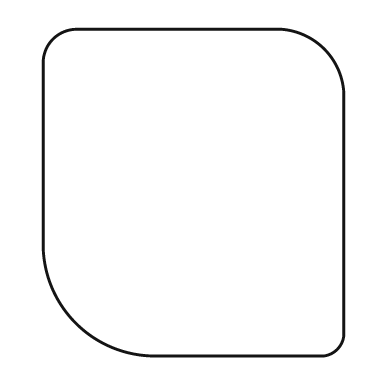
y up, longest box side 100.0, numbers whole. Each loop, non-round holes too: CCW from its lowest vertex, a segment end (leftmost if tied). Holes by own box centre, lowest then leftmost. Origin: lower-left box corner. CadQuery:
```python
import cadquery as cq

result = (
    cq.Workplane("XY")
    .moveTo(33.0, 0.0)
    .lineTo(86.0, 0.0)
    .threePointArc((90.0, 2.0), (92.0, 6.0))
    .lineTo(92.0, 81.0)
    .threePointArc((86.0, 94.0), (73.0, 100.0))
    .lineTo(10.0, 100.0)
    .threePointArc((3.0, 97.0), (0.0, 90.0))
    .lineTo(0.0, 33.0)
    .threePointArc((10.0, 10.0), (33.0, 0.0))
    .close()
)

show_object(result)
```